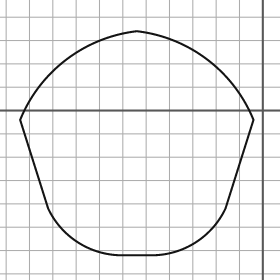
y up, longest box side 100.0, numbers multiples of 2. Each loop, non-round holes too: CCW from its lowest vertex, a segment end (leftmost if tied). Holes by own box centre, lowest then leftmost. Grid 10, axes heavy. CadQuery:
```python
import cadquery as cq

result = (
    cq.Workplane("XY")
    .moveTo(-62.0, -62.0)
    .lineTo(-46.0, -62.0)
    .threePointArc((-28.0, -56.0), (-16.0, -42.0))
    .lineTo(-4.0, -4.0)
    .threePointArc((-24.0, 22.0), (-54.0, 34.0))
    .threePointArc((-84.0, 22.0), (-104.0, -4.0))
    .lineTo(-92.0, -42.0)
    .threePointArc((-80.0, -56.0), (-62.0, -62.0))
    .close()
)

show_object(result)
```